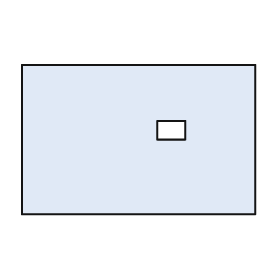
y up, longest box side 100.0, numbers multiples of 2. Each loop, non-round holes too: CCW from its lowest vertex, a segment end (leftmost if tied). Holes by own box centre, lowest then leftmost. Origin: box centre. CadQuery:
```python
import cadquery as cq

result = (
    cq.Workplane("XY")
    .moveTo(-50.0, -32.0)
    .lineTo(50.0, -32.0)
    .lineTo(50.0, 32.0)
    .lineTo(-50.0, 32.0)
    .close()
    .moveTo(8.0, 0.0)
    .lineTo(20.0, 0.0)
    .lineTo(20.0, 8.0)
    .lineTo(8.0, 8.0)
    .close()
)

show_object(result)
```